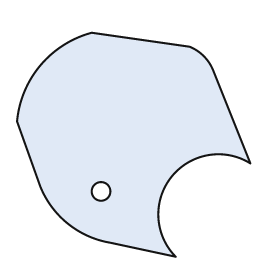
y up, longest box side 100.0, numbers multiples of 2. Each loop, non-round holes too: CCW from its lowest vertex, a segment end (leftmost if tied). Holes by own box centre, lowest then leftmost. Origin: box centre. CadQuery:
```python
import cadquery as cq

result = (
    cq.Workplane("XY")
    .moveTo(18.0, -48.0)
    .threePointArc((16.0, -14.0), (50.0, -8.0))
    .lineTo(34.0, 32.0)
    .threePointArc((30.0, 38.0), (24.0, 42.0))
    .lineTo(-18.0, 48.0)
    .threePointArc((-40.0, 34.0), (-50.0, 10.0))
    .lineTo(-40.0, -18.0)
    .threePointArc((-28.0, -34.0), (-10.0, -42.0))
    .close()
    .moveTo(-14.0, -20.0)
    .circle(4.0)
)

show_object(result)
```